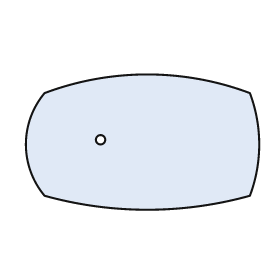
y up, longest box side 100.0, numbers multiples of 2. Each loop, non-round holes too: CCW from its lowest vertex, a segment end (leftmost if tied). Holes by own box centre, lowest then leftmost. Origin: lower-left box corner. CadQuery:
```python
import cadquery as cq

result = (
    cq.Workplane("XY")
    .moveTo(8.0, 6.0)
    .threePointArc((52.0, 0.0), (96.0, 6.0))
    .threePointArc((100.0, 28.0), (96.0, 50.0))
    .threePointArc((52.0, 58.0), (8.0, 50.0))
    .threePointArc((0.0, 28.0), (8.0, 6.0))
    .close()
    .moveTo(32.0, 30.0)
    .circle(2.0)
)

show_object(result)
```